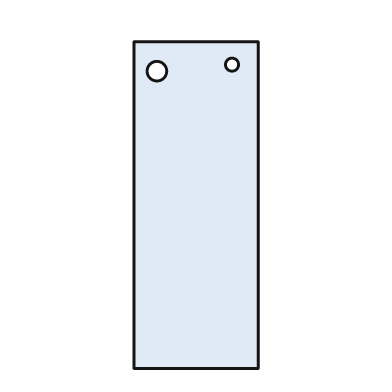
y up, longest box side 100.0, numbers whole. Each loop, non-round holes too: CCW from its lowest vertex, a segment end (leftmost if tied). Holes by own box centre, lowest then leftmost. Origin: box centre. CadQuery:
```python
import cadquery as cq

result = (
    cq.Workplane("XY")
    .moveTo(-19.0, -50.0)
    .lineTo(19.0, -50.0)
    .lineTo(19.0, 50.0)
    .lineTo(-19.0, 50.0)
    .close()
    .moveTo(-12.0, 41.0)
    .circle(3.0)
    .moveTo(11.0, 43.0)
    .circle(2.0)
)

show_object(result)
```